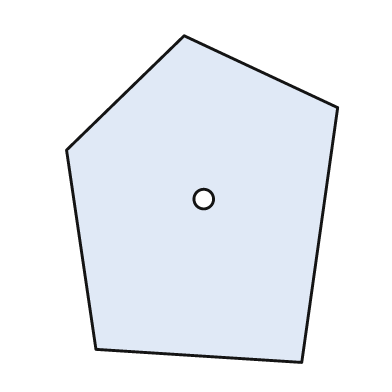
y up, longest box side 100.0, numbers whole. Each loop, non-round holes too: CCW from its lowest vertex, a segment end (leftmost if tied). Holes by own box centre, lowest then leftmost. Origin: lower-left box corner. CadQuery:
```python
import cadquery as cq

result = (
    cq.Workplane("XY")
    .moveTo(72.0, 0.0)
    .lineTo(83.0, 78.0)
    .lineTo(36.0, 100.0)
    .lineTo(0.0, 65.0)
    .lineTo(9.0, 4.0)
    .close()
    .moveTo(42.0, 50.0)
    .circle(3.0)
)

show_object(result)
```